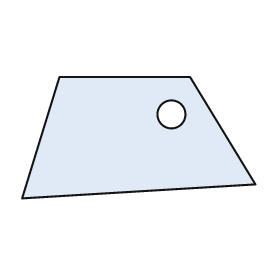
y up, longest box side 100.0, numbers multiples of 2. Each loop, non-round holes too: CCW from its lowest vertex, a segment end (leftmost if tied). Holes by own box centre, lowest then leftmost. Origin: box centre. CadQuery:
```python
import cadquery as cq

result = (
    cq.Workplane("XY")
    .moveTo(-50.0, -26.0)
    .lineTo(50.0, -20.0)
    .lineTo(22.0, 26.0)
    .lineTo(-34.0, 26.0)
    .close()
    .moveTo(14.0, 10.0)
    .circle(6.0)
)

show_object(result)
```